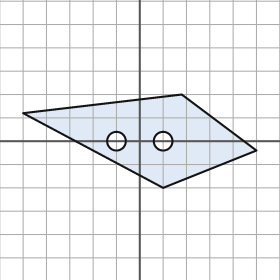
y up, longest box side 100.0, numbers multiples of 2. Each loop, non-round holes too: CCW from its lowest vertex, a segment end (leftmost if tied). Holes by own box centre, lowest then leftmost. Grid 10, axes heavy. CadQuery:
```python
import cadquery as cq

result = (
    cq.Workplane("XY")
    .moveTo(10.0, -20.0)
    .lineTo(50.0, -4.0)
    .lineTo(18.0, 20.0)
    .lineTo(-50.0, 12.0)
    .close()
    .moveTo(-10.0, 0.0)
    .circle(4.0)
    .moveTo(10.0, 0.0)
    .circle(4.0)
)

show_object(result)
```